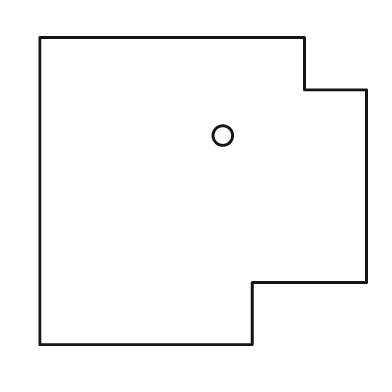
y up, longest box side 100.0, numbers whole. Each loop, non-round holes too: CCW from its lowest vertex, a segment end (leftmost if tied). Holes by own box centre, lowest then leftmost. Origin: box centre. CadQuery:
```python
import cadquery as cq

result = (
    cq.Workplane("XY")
    .moveTo(-50.0, -47.0)
    .lineTo(15.0, -47.0)
    .lineTo(15.0, -28.0)
    .lineTo(50.0, -28.0)
    .lineTo(50.0, 31.0)
    .lineTo(31.0, 31.0)
    .lineTo(31.0, 47.0)
    .lineTo(-50.0, 47.0)
    .close()
    .moveTo(6.0, 17.0)
    .circle(3.0)
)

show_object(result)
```